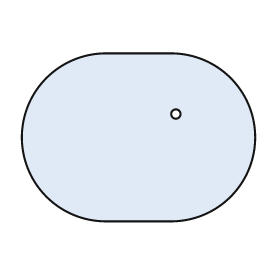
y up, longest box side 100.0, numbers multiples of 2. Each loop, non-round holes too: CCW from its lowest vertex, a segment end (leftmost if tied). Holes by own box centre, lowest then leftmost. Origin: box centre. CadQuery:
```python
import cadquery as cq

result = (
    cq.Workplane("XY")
    .moveTo(-14.0, -36.0)
    .lineTo(14.0, -36.0)
    .threePointArc((50.0, 0.0), (14.0, 36.0))
    .lineTo(-14.0, 36.0)
    .threePointArc((-50.0, 0.0), (-14.0, -36.0))
    .close()
    .moveTo(16.0, 10.0)
    .circle(2.0)
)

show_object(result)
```